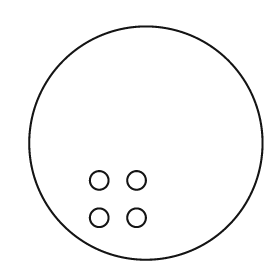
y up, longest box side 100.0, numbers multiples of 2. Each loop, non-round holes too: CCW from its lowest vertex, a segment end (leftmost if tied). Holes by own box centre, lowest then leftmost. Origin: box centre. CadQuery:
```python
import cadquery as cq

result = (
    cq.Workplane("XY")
    .moveTo(0.0, 0.0)
    .circle(50.0)
    .moveTo(-20.0, -32.0)
    .circle(4.0)
    .moveTo(-4.0, -32.0)
    .circle(4.0)
    .moveTo(-20.0, -16.0)
    .circle(4.0)
    .moveTo(-4.0, -16.0)
    .circle(4.0)
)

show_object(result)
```